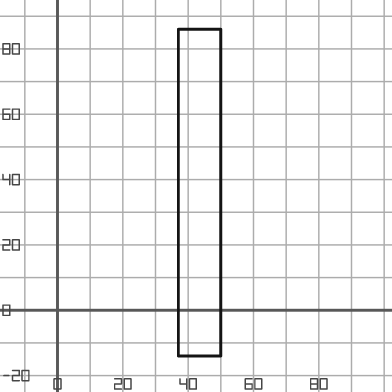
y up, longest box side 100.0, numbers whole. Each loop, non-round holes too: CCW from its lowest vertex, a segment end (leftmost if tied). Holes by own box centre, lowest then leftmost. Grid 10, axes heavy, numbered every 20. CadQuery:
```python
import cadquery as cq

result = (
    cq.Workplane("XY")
    .moveTo(37.0, -14.0)
    .lineTo(50.0, -14.0)
    .lineTo(50.0, 86.0)
    .lineTo(37.0, 86.0)
    .close()
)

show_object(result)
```